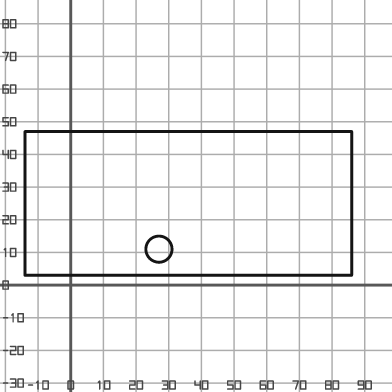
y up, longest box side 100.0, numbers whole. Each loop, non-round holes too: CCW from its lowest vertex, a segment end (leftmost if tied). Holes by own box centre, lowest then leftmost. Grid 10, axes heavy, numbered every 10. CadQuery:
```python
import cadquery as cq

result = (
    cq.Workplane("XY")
    .moveTo(-14.0, 3.0)
    .lineTo(86.0, 3.0)
    .lineTo(86.0, 47.0)
    .lineTo(-14.0, 47.0)
    .close()
    .moveTo(27.0, 11.0)
    .circle(4.0)
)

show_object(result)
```